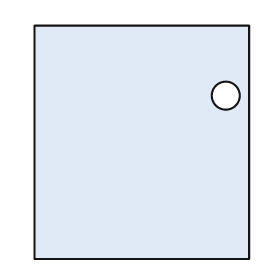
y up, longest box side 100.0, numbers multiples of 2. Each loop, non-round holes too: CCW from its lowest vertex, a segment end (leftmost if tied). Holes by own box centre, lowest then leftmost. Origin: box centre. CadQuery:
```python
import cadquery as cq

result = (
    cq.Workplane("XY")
    .moveTo(-46.0, -50.0)
    .lineTo(46.0, -50.0)
    .lineTo(46.0, 50.0)
    .lineTo(-46.0, 50.0)
    .close()
    .moveTo(36.0, 20.0)
    .circle(6.0)
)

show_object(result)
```